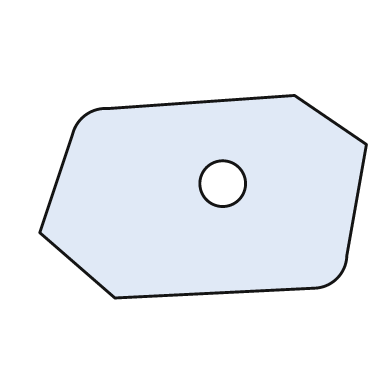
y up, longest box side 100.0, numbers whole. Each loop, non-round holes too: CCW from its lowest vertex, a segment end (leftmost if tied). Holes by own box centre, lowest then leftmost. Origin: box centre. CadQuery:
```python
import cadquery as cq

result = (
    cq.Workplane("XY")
    .moveTo(-27.0, -31.0)
    .lineTo(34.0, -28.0)
    .threePointArc((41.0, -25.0), (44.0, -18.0))
    .lineTo(50.0, 16.0)
    .lineTo(28.0, 31.0)
    .lineTo(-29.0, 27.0)
    .threePointArc((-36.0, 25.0), (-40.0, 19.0))
    .lineTo(-50.0, -11.0)
    .close()
    .moveTo(6.0, 4.0)
    .circle(7.0)
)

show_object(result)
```